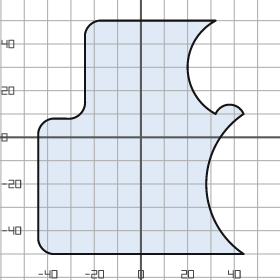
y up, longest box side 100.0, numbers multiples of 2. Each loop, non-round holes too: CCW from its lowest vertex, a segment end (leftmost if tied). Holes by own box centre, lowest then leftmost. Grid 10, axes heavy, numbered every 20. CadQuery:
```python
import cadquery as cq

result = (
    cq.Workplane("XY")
    .moveTo(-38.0, -50.0)
    .lineTo(44.0, -50.0)
    .threePointArc((28.0, -20.0), (44.0, 10.0))
    .threePointArc((38.0, 14.0), (32.0, 10.0))
    .threePointArc((20.0, 30.0), (32.0, 50.0))
    .lineTo(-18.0, 50.0)
    .threePointArc((-22.0, 48.0), (-24.0, 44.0))
    .lineTo(-24.0, 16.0)
    .threePointArc((-26.0, 10.0), (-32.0, 8.0))
    .lineTo(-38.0, 8.0)
    .threePointArc((-42.0, 6.0), (-44.0, 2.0))
    .lineTo(-44.0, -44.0)
    .threePointArc((-42.0, -48.0), (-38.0, -50.0))
    .close()
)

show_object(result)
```